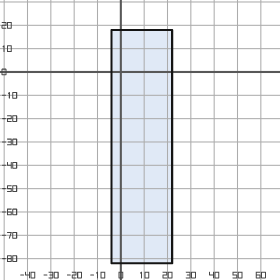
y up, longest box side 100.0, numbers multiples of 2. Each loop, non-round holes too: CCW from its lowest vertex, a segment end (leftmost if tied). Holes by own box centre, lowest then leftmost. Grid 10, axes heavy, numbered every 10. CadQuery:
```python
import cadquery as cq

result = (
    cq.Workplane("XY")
    .moveTo(-4.0, -82.0)
    .lineTo(22.0, -82.0)
    .lineTo(22.0, 18.0)
    .lineTo(-4.0, 18.0)
    .close()
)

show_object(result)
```